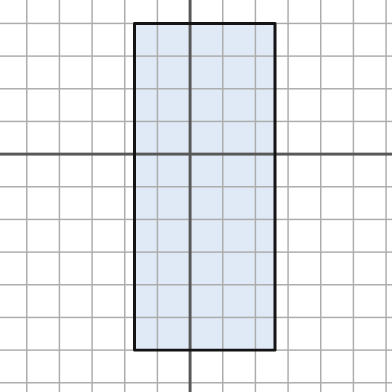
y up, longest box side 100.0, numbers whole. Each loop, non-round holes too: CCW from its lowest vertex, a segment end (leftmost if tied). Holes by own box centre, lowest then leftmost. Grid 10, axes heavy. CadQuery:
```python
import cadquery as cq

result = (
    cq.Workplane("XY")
    .moveTo(-17.0, -60.0)
    .lineTo(26.0, -60.0)
    .lineTo(26.0, 40.0)
    .lineTo(-17.0, 40.0)
    .close()
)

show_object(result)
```